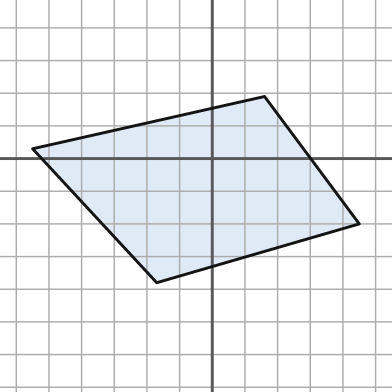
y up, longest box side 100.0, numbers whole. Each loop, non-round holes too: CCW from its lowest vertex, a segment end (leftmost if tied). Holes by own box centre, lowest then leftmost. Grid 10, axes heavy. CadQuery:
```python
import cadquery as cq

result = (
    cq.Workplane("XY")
    .moveTo(-17.0, -38.0)
    .lineTo(45.0, -20.0)
    .lineTo(16.0, 19.0)
    .lineTo(-55.0, 3.0)
    .close()
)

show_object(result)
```